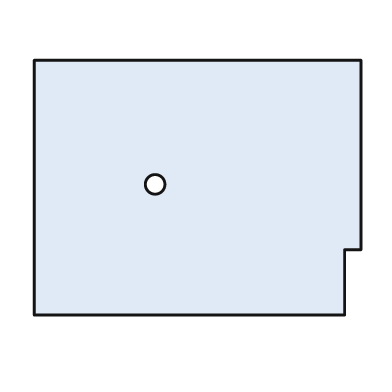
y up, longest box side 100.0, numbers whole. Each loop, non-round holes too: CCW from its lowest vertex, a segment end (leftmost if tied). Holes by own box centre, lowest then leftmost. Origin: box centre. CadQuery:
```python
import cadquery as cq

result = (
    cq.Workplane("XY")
    .moveTo(-50.0, -39.0)
    .lineTo(45.0, -39.0)
    .lineTo(45.0, -19.0)
    .lineTo(50.0, -19.0)
    .lineTo(50.0, 39.0)
    .lineTo(-50.0, 39.0)
    .close()
    .moveTo(-13.0, 1.0)
    .circle(3.0)
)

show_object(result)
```